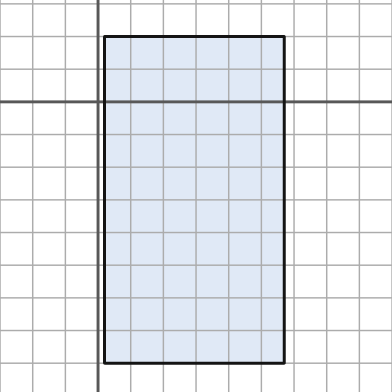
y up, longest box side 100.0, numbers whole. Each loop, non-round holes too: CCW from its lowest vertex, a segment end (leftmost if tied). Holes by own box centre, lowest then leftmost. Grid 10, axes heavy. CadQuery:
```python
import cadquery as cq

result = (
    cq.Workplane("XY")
    .moveTo(2.0, -80.0)
    .lineTo(57.0, -80.0)
    .lineTo(57.0, 20.0)
    .lineTo(2.0, 20.0)
    .close()
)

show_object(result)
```